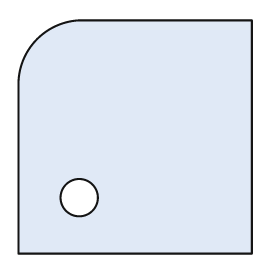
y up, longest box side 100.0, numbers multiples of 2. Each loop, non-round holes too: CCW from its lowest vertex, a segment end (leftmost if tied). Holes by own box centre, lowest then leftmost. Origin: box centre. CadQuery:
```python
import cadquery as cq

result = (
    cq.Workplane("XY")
    .moveTo(-50.0, -50.0)
    .lineTo(50.0, -50.0)
    .lineTo(50.0, 50.0)
    .lineTo(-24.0, 50.0)
    .threePointArc((-42.0, 42.0), (-50.0, 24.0))
    .close()
    .moveTo(-24.0, -26.0)
    .circle(8.0)
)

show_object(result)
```